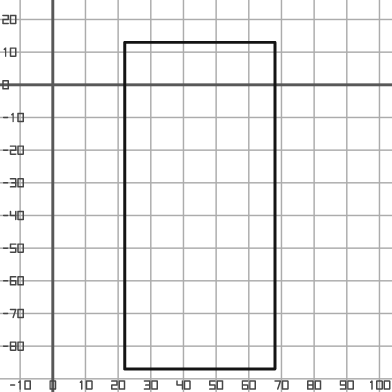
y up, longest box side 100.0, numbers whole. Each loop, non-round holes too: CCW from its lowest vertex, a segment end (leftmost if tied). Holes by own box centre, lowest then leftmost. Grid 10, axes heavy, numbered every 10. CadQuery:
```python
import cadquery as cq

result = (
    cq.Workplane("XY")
    .moveTo(22.0, -87.0)
    .lineTo(68.0, -87.0)
    .lineTo(68.0, 13.0)
    .lineTo(22.0, 13.0)
    .close()
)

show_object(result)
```